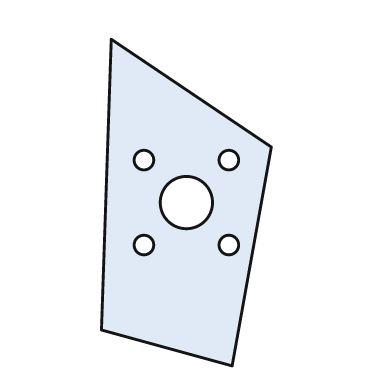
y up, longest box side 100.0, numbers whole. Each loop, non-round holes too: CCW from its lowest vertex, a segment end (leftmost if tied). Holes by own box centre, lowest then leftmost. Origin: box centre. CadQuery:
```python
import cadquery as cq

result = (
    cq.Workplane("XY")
    .moveTo(14.0, -50.0)
    .lineTo(26.0, 17.0)
    .lineTo(-23.0, 50.0)
    .lineTo(-26.0, -39.0)
    .close()
    .moveTo(-13.0, -13.0)
    .circle(3.0)
    .moveTo(13.0, -13.0)
    .circle(3.0)
    .moveTo(0.0, 0.0)
    .circle(8.0)
    .moveTo(-13.0, 13.0)
    .circle(3.0)
    .moveTo(13.0, 13.0)
    .circle(3.0)
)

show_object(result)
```